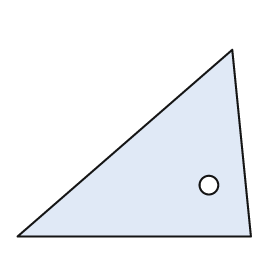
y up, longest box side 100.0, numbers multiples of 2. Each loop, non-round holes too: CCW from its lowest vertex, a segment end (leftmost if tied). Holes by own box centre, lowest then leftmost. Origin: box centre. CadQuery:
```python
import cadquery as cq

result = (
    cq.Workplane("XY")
    .moveTo(-50.0, -40.0)
    .lineTo(50.0, -40.0)
    .lineTo(42.0, 40.0)
    .close()
    .moveTo(32.0, -18.0)
    .circle(4.0)
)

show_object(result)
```